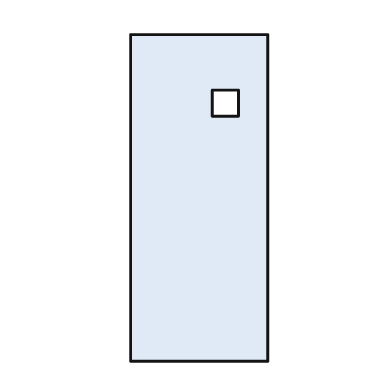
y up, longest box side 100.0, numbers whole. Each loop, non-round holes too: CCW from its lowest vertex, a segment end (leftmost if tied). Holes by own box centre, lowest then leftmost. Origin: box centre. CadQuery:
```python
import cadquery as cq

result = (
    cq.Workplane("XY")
    .moveTo(-21.0, -50.0)
    .lineTo(21.0, -50.0)
    .lineTo(21.0, 50.0)
    .lineTo(-21.0, 50.0)
    .close()
    .moveTo(4.0, 25.0)
    .lineTo(12.0, 25.0)
    .lineTo(12.0, 33.0)
    .lineTo(4.0, 33.0)
    .close()
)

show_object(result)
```